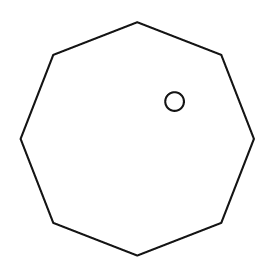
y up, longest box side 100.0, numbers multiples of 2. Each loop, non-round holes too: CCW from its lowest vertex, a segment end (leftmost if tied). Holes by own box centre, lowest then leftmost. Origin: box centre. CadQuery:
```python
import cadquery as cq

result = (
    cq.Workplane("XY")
    .moveTo(0.0, -50.0)
    .lineTo(36.0, -36.0)
    .lineTo(50.0, 0.0)
    .lineTo(36.0, 36.0)
    .lineTo(0.0, 50.0)
    .lineTo(-36.0, 36.0)
    .lineTo(-50.0, 0.0)
    .lineTo(-36.0, -36.0)
    .close()
    .moveTo(16.0, 16.0)
    .circle(4.0)
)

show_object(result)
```